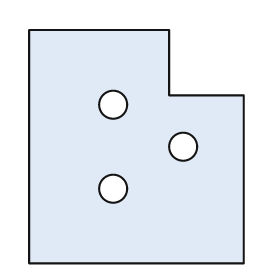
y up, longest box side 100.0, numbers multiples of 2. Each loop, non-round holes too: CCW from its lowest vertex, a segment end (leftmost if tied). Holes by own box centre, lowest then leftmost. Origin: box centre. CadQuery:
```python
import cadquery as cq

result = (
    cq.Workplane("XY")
    .moveTo(-46.0, -50.0)
    .lineTo(46.0, -50.0)
    .lineTo(46.0, 22.0)
    .lineTo(14.0, 22.0)
    .lineTo(14.0, 50.0)
    .lineTo(-46.0, 50.0)
    .close()
    .moveTo(-10.0, -18.0)
    .circle(6.0)
    .moveTo(20.0, 0.0)
    .circle(6.0)
    .moveTo(-10.0, 18.0)
    .circle(6.0)
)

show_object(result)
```